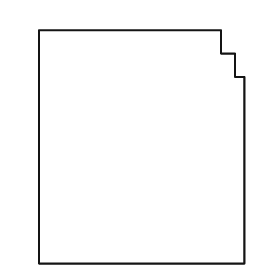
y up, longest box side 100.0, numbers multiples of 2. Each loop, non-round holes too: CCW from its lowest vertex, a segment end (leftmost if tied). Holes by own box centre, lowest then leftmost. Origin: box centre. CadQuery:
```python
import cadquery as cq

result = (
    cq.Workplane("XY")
    .moveTo(-44.0, -50.0)
    .lineTo(44.0, -50.0)
    .lineTo(44.0, 30.0)
    .lineTo(40.0, 30.0)
    .lineTo(40.0, 40.0)
    .lineTo(34.0, 40.0)
    .lineTo(34.0, 50.0)
    .lineTo(-44.0, 50.0)
    .close()
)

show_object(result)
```